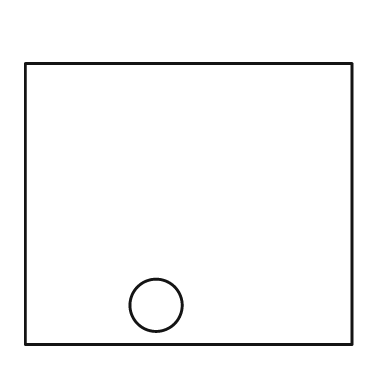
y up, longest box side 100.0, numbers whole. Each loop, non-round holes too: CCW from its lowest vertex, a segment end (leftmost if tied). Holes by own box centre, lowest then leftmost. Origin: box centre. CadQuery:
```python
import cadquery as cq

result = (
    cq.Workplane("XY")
    .moveTo(-50.0, -43.0)
    .lineTo(50.0, -43.0)
    .lineTo(50.0, 43.0)
    .lineTo(-50.0, 43.0)
    .close()
    .moveTo(-10.0, -31.0)
    .circle(8.0)
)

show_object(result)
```